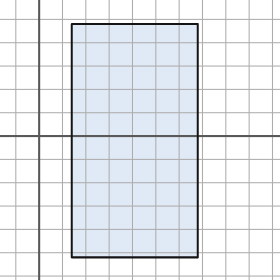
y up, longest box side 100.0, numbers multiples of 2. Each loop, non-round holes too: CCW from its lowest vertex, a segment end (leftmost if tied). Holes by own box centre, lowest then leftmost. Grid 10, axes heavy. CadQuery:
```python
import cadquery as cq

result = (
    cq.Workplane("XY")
    .moveTo(14.0, -52.0)
    .lineTo(68.0, -52.0)
    .lineTo(68.0, 48.0)
    .lineTo(14.0, 48.0)
    .close()
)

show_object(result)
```